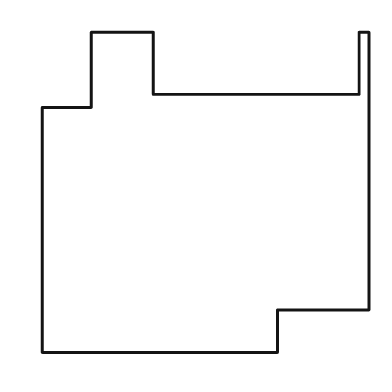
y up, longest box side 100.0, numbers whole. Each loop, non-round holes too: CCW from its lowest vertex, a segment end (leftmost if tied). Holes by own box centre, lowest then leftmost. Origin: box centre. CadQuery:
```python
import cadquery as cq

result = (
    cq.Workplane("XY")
    .moveTo(-50.0, -49.0)
    .lineTo(22.0, -49.0)
    .lineTo(22.0, -36.0)
    .lineTo(50.0, -36.0)
    .lineTo(50.0, 49.0)
    .lineTo(47.0, 49.0)
    .lineTo(47.0, 30.0)
    .lineTo(-16.0, 30.0)
    .lineTo(-16.0, 49.0)
    .lineTo(-35.0, 49.0)
    .lineTo(-35.0, 26.0)
    .lineTo(-50.0, 26.0)
    .close()
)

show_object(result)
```